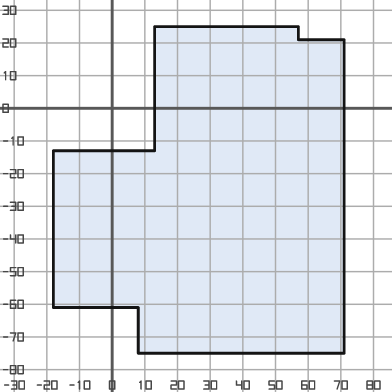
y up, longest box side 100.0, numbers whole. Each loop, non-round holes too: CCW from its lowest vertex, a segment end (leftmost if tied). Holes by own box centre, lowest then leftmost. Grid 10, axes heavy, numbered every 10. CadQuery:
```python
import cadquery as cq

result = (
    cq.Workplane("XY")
    .moveTo(8.0, -75.0)
    .lineTo(71.0, -75.0)
    .lineTo(71.0, 21.0)
    .lineTo(57.0, 21.0)
    .lineTo(57.0, 25.0)
    .lineTo(13.0, 25.0)
    .lineTo(13.0, -13.0)
    .lineTo(-18.0, -13.0)
    .lineTo(-18.0, -61.0)
    .lineTo(8.0, -61.0)
    .close()
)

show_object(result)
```